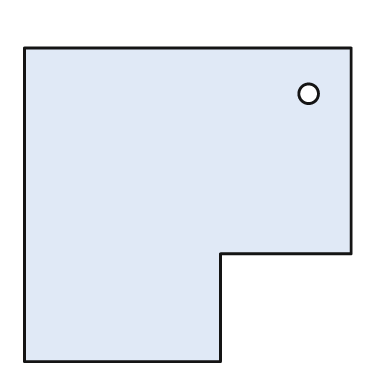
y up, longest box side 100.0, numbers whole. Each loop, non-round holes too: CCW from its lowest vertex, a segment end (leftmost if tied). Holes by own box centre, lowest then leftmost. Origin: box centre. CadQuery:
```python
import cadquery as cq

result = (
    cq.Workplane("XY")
    .moveTo(-50.0, -48.0)
    .lineTo(10.0, -48.0)
    .lineTo(10.0, -15.0)
    .lineTo(50.0, -15.0)
    .lineTo(50.0, 48.0)
    .lineTo(-50.0, 48.0)
    .close()
    .moveTo(37.0, 34.0)
    .circle(3.0)
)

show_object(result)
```